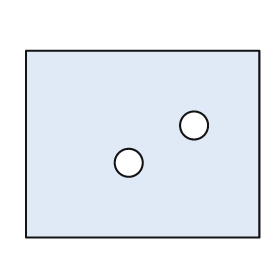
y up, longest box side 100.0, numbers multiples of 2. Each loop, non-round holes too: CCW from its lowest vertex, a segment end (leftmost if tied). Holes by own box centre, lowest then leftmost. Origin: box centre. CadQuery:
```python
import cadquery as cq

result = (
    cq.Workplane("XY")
    .moveTo(-50.0, -40.0)
    .lineTo(50.0, -40.0)
    .lineTo(50.0, 40.0)
    .lineTo(-50.0, 40.0)
    .close()
    .moveTo(-6.0, -8.0)
    .circle(6.0)
    .moveTo(22.0, 8.0)
    .circle(6.0)
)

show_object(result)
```